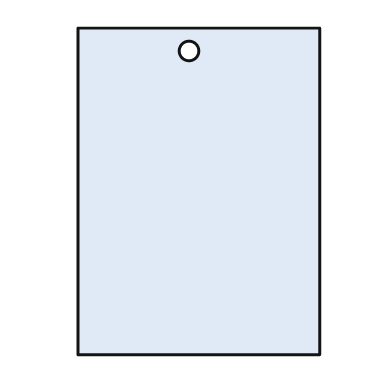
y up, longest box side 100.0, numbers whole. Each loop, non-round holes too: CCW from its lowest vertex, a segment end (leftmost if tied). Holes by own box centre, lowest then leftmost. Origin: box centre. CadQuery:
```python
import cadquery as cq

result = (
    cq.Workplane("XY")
    .moveTo(-37.0, -50.0)
    .lineTo(37.0, -50.0)
    .lineTo(37.0, 50.0)
    .lineTo(-37.0, 50.0)
    .close()
    .moveTo(-3.0, 43.0)
    .circle(3.0)
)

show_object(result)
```